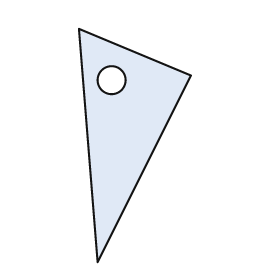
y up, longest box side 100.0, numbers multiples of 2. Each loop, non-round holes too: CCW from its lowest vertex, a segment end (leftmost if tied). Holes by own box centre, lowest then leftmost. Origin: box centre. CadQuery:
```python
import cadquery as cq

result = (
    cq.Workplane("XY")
    .moveTo(-16.0, -50.0)
    .lineTo(24.0, 30.0)
    .lineTo(-24.0, 50.0)
    .close()
    .moveTo(-10.0, 28.0)
    .circle(6.0)
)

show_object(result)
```